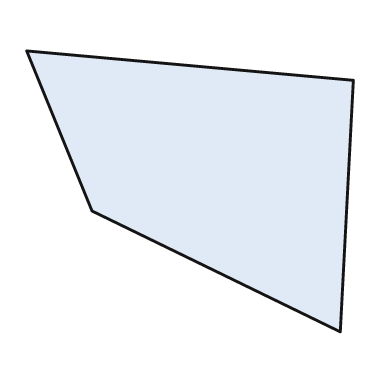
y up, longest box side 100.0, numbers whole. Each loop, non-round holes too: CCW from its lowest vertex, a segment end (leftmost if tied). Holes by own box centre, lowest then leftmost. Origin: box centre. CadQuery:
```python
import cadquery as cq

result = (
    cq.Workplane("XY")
    .moveTo(46.0, -43.0)
    .lineTo(50.0, 34.0)
    .lineTo(-50.0, 43.0)
    .lineTo(-30.0, -6.0)
    .close()
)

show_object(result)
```